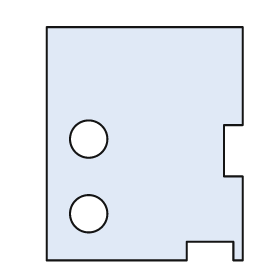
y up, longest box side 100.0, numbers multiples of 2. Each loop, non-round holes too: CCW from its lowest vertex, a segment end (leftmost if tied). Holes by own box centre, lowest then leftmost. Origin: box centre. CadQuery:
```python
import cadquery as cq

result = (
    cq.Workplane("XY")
    .moveTo(-42.0, -50.0)
    .lineTo(18.0, -50.0)
    .lineTo(18.0, -42.0)
    .lineTo(38.0, -42.0)
    .lineTo(38.0, -50.0)
    .lineTo(42.0, -50.0)
    .lineTo(42.0, -14.0)
    .lineTo(34.0, -14.0)
    .lineTo(34.0, 8.0)
    .lineTo(42.0, 8.0)
    .lineTo(42.0, 50.0)
    .lineTo(-42.0, 50.0)
    .close()
    .moveTo(-24.0, -30.0)
    .circle(8.0)
    .moveTo(-24.0, 2.0)
    .circle(8.0)
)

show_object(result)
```